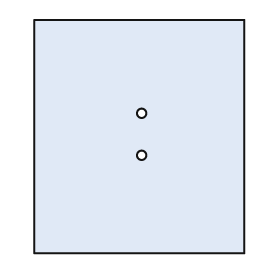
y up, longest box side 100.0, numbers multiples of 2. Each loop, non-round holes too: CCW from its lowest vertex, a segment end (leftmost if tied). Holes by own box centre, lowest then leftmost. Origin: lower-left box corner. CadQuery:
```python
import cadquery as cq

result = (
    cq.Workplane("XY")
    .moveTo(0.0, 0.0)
    .lineTo(90.0, 0.0)
    .lineTo(90.0, 100.0)
    .lineTo(0.0, 100.0)
    .close()
    .moveTo(46.0, 42.0)
    .circle(2.0)
    .moveTo(46.0, 60.0)
    .circle(2.0)
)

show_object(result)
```